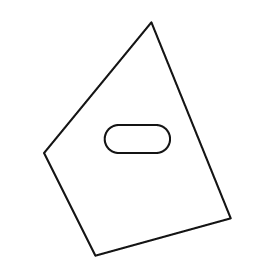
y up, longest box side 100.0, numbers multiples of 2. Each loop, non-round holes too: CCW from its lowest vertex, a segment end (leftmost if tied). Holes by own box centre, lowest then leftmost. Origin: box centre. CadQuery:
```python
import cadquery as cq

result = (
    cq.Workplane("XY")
    .moveTo(-18.0, -50.0)
    .lineTo(40.0, -34.0)
    .lineTo(6.0, 50.0)
    .lineTo(-40.0, -6.0)
    .close()
    .moveTo(-8.0, -6.0)
    .lineTo(8.0, -6.0)
    .threePointArc((14.0, 0.0), (8.0, 6.0))
    .lineTo(-8.0, 6.0)
    .threePointArc((-14.0, 0.0), (-8.0, -6.0))
    .close()
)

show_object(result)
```